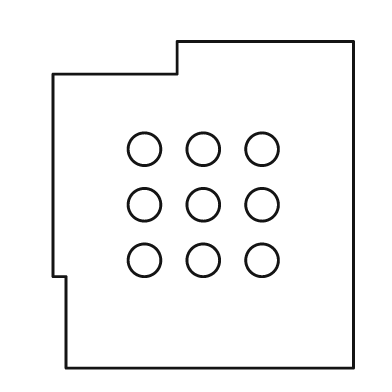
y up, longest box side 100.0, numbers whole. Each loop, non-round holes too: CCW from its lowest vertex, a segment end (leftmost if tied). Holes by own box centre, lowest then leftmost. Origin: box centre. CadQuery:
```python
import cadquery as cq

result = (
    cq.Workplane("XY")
    .moveTo(-42.0, -50.0)
    .lineTo(46.0, -50.0)
    .lineTo(46.0, 50.0)
    .lineTo(-8.0, 50.0)
    .lineTo(-8.0, 40.0)
    .lineTo(-46.0, 40.0)
    .lineTo(-46.0, -22.0)
    .lineTo(-42.0, -22.0)
    .close()
    .moveTo(-18.0, -17.0)
    .circle(5.0)
    .moveTo(0.0, -17.0)
    .circle(5.0)
    .moveTo(18.0, -17.0)
    .circle(5.0)
    .moveTo(-18.0, 0.0)
    .circle(5.0)
    .moveTo(0.0, 0.0)
    .circle(5.0)
    .moveTo(18.0, 0.0)
    .circle(5.0)
    .moveTo(-18.0, 17.0)
    .circle(5.0)
    .moveTo(0.0, 17.0)
    .circle(5.0)
    .moveTo(18.0, 17.0)
    .circle(5.0)
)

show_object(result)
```